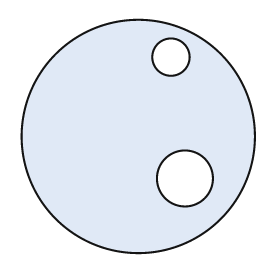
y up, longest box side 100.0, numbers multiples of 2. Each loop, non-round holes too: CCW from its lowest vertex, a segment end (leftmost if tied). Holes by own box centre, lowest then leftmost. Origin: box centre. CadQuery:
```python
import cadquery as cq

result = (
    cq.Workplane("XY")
    .moveTo(0.0, 0.0)
    .circle(50.0)
    .moveTo(20.0, -18.0)
    .circle(12.0)
    .moveTo(14.0, 34.0)
    .circle(8.0)
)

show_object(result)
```